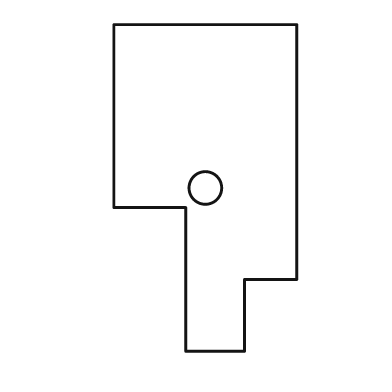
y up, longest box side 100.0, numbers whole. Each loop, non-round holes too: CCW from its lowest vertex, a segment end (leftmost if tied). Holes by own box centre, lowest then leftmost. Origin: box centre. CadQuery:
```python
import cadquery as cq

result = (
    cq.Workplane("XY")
    .moveTo(-6.0, -50.0)
    .lineTo(12.0, -50.0)
    .lineTo(12.0, -28.0)
    .lineTo(28.0, -28.0)
    .lineTo(28.0, 50.0)
    .lineTo(-28.0, 50.0)
    .lineTo(-28.0, -6.0)
    .lineTo(-6.0, -6.0)
    .close()
    .moveTo(0.0, 0.0)
    .circle(5.0)
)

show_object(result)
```